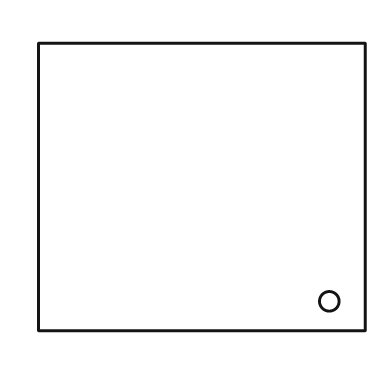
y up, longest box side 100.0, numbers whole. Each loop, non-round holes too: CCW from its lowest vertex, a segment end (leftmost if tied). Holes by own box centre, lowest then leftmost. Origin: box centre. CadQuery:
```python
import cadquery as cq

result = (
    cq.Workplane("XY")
    .moveTo(-50.0, -44.0)
    .lineTo(50.0, -44.0)
    .lineTo(50.0, 44.0)
    .lineTo(-50.0, 44.0)
    .close()
    .moveTo(39.0, -35.0)
    .circle(3.0)
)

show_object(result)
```